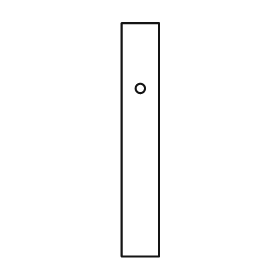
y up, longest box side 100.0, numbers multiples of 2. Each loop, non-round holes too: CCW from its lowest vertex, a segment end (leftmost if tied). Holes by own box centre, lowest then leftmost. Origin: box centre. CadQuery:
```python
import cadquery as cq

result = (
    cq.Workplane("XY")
    .moveTo(-8.0, -50.0)
    .lineTo(8.0, -50.0)
    .lineTo(8.0, 50.0)
    .lineTo(-8.0, 50.0)
    .close()
    .moveTo(0.0, 22.0)
    .circle(2.0)
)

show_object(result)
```